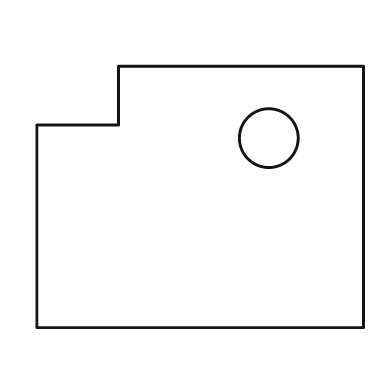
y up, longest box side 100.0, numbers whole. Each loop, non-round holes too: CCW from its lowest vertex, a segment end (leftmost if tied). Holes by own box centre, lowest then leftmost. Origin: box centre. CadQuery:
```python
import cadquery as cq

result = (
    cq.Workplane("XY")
    .moveTo(-50.0, -40.0)
    .lineTo(50.0, -40.0)
    .lineTo(50.0, 40.0)
    .lineTo(-25.0, 40.0)
    .lineTo(-25.0, 22.0)
    .lineTo(-50.0, 22.0)
    .close()
    .moveTo(21.0, 18.0)
    .circle(9.0)
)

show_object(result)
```